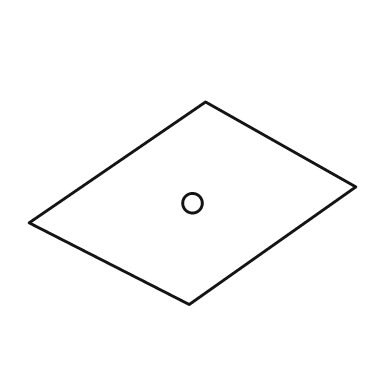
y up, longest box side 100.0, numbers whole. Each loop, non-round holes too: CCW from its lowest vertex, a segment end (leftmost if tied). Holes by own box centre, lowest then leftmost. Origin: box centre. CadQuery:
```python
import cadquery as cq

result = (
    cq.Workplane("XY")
    .moveTo(-1.0, -31.0)
    .lineTo(50.0, 5.0)
    .lineTo(4.0, 31.0)
    .lineTo(-50.0, -6.0)
    .close()
    .moveTo(0.0, 0.0)
    .circle(3.0)
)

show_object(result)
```